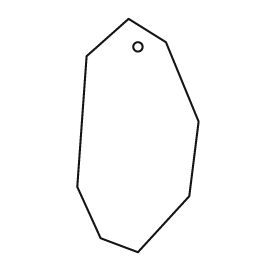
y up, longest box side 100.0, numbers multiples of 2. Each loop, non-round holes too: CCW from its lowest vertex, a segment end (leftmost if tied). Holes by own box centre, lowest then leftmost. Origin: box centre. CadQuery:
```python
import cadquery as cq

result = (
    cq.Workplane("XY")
    .moveTo(0.0, -50.0)
    .lineTo(22.0, -26.0)
    .lineTo(26.0, 6.0)
    .lineTo(12.0, 40.0)
    .lineTo(-4.0, 50.0)
    .lineTo(-22.0, 34.0)
    .lineTo(-26.0, -22.0)
    .lineTo(-16.0, -44.0)
    .close()
    .moveTo(0.0, 38.0)
    .circle(2.0)
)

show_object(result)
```